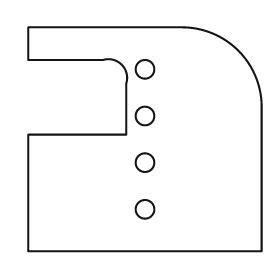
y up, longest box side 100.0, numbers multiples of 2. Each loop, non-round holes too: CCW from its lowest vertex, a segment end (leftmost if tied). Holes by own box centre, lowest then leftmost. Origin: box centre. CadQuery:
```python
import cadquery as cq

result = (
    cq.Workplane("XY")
    .moveTo(-50.0, -48.0)
    .lineTo(50.0, -48.0)
    .lineTo(50.0, 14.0)
    .threePointArc((40.0, 38.0), (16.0, 48.0))
    .lineTo(-50.0, 48.0)
    .lineTo(-50.0, 34.0)
    .lineTo(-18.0, 34.0)
    .threePointArc((-10.0, 32.0), (-8.0, 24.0))
    .lineTo(-8.0, 2.0)
    .lineTo(-50.0, 2.0)
    .close()
    .moveTo(0.0, -30.0)
    .circle(4.0)
    .moveTo(0.0, -10.0)
    .circle(4.0)
    .moveTo(0.0, 10.0)
    .circle(4.0)
    .moveTo(0.0, 30.0)
    .circle(4.0)
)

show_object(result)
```